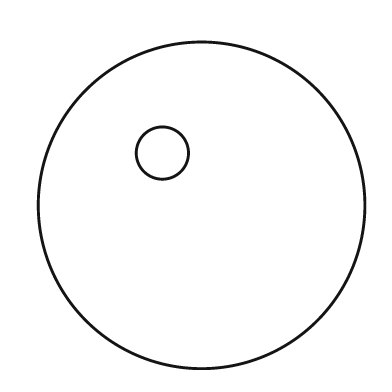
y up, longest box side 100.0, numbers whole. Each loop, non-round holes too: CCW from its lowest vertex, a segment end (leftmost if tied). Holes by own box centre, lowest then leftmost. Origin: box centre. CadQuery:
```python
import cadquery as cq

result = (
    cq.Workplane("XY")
    .moveTo(0.0, 0.0)
    .circle(50.0)
    .moveTo(-12.0, 16.0)
    .circle(8.0)
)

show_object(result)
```